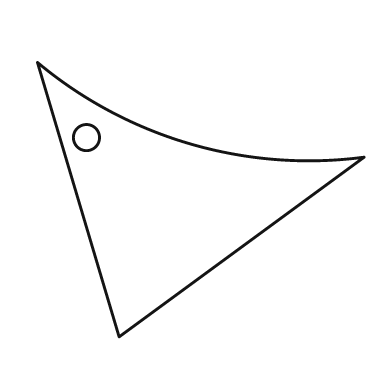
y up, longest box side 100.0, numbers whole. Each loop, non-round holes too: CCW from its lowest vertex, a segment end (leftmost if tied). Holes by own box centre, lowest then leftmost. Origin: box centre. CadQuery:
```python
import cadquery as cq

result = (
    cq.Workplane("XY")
    .moveTo(-25.0, -42.0)
    .lineTo(50.0, 13.0)
    .threePointArc((-3.0, 17.0), (-50.0, 42.0))
    .close()
    .moveTo(-35.0, 19.0)
    .circle(4.0)
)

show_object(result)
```